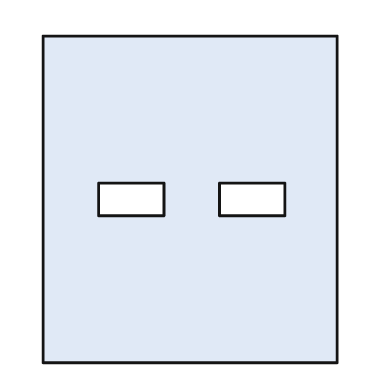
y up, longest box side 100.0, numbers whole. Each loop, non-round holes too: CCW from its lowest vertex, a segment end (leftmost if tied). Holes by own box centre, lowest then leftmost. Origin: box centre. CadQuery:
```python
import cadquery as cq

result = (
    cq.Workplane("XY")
    .moveTo(-45.0, -50.0)
    .lineTo(45.0, -50.0)
    .lineTo(45.0, 50.0)
    .lineTo(-45.0, 50.0)
    .close()
    .moveTo(-28.0, -5.0)
    .lineTo(-8.0, -5.0)
    .lineTo(-8.0, 5.0)
    .lineTo(-28.0, 5.0)
    .close()
    .moveTo(9.0, -5.0)
    .lineTo(29.0, -5.0)
    .lineTo(29.0, 5.0)
    .lineTo(9.0, 5.0)
    .close()
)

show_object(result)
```